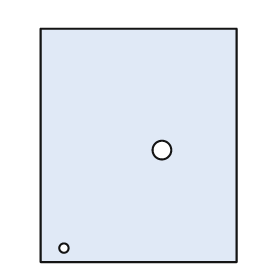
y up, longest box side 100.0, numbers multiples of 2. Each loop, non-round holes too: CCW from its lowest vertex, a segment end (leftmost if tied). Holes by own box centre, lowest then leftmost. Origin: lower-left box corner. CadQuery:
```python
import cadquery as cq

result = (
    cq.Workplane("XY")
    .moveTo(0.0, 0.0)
    .lineTo(84.0, 0.0)
    .lineTo(84.0, 100.0)
    .lineTo(0.0, 100.0)
    .close()
    .moveTo(10.0, 6.0)
    .circle(2.0)
    .moveTo(52.0, 48.0)
    .circle(4.0)
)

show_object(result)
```